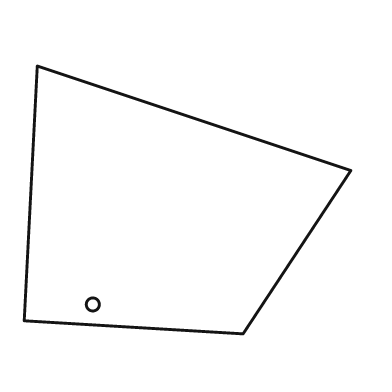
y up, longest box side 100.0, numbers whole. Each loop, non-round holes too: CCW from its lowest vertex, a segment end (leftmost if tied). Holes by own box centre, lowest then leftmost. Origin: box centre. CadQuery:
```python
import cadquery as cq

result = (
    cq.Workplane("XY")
    .moveTo(17.0, -41.0)
    .lineTo(50.0, 9.0)
    .lineTo(-46.0, 41.0)
    .lineTo(-50.0, -37.0)
    .close()
    .moveTo(-29.0, -32.0)
    .circle(2.0)
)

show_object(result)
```